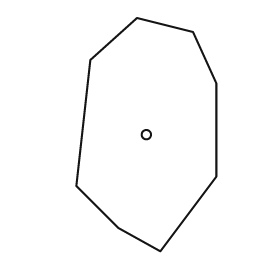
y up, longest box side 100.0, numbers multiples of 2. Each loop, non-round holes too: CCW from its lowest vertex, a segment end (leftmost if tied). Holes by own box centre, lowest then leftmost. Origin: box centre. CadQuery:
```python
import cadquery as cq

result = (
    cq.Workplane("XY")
    .moveTo(6.0, -50.0)
    .lineTo(30.0, -18.0)
    .lineTo(30.0, 22.0)
    .lineTo(20.0, 44.0)
    .lineTo(-4.0, 50.0)
    .lineTo(-24.0, 32.0)
    .lineTo(-30.0, -22.0)
    .lineTo(-12.0, -40.0)
    .close()
    .moveTo(0.0, 0.0)
    .circle(2.0)
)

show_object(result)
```